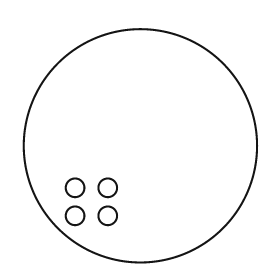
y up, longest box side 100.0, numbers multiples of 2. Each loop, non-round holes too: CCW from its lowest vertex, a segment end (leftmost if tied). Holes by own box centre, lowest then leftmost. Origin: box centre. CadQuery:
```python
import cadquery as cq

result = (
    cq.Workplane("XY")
    .moveTo(0.0, 0.0)
    .circle(50.0)
    .moveTo(-28.0, -30.0)
    .circle(4.0)
    .moveTo(-14.0, -30.0)
    .circle(4.0)
    .moveTo(-28.0, -18.0)
    .circle(4.0)
    .moveTo(-14.0, -18.0)
    .circle(4.0)
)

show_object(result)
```